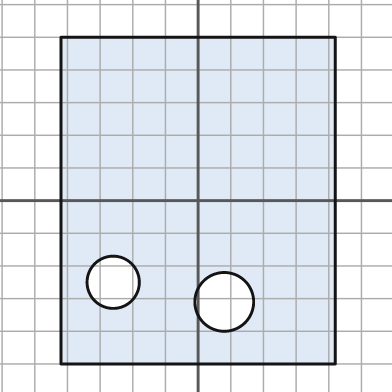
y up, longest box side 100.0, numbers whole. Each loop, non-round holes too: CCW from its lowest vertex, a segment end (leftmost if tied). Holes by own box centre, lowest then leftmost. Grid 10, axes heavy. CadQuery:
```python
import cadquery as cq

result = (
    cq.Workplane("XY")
    .moveTo(-42.0, -50.0)
    .lineTo(42.0, -50.0)
    .lineTo(42.0, 50.0)
    .lineTo(-42.0, 50.0)
    .close()
    .moveTo(8.0, -31.0)
    .circle(9.0)
    .moveTo(-26.0, -25.0)
    .circle(8.0)
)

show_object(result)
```